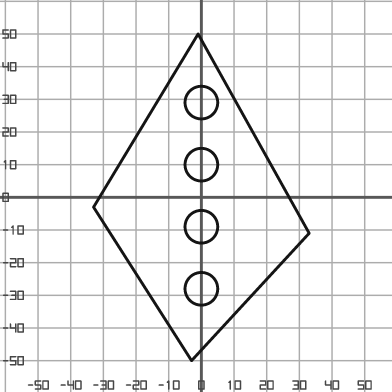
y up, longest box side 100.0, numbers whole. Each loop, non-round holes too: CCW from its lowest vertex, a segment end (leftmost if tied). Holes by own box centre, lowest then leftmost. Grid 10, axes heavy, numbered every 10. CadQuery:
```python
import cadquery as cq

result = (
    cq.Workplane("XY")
    .moveTo(-3.0, -50.0)
    .lineTo(33.0, -11.0)
    .lineTo(-1.0, 50.0)
    .lineTo(-33.0, -3.0)
    .close()
    .moveTo(0.0, -28.0)
    .circle(5.0)
    .moveTo(0.0, -9.0)
    .circle(5.0)
    .moveTo(0.0, 10.0)
    .circle(5.0)
    .moveTo(0.0, 29.0)
    .circle(5.0)
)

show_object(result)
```